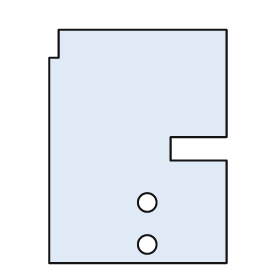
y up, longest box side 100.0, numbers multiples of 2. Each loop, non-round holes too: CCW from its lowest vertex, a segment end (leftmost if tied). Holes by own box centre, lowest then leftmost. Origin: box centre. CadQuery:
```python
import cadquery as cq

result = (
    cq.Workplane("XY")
    .moveTo(-38.0, -50.0)
    .lineTo(38.0, -50.0)
    .lineTo(38.0, -6.0)
    .lineTo(14.0, -6.0)
    .lineTo(14.0, 4.0)
    .lineTo(38.0, 4.0)
    .lineTo(38.0, 50.0)
    .lineTo(-34.0, 50.0)
    .lineTo(-34.0, 38.0)
    .lineTo(-38.0, 38.0)
    .close()
    .moveTo(4.0, -42.0)
    .circle(4.0)
    .moveTo(4.0, -24.0)
    .circle(4.0)
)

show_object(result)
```